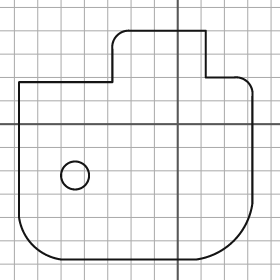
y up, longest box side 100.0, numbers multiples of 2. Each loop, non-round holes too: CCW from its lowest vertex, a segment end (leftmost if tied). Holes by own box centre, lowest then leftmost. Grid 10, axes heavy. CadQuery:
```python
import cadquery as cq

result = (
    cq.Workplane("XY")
    .moveTo(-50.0, -58.0)
    .lineTo(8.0, -58.0)
    .threePointArc((24.0, -50.0), (32.0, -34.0))
    .lineTo(32.0, 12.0)
    .threePointArc((30.0, 18.0), (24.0, 20.0))
    .lineTo(12.0, 20.0)
    .lineTo(12.0, 40.0)
    .lineTo(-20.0, 40.0)
    .threePointArc((-26.0, 38.0), (-28.0, 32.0))
    .lineTo(-28.0, 18.0)
    .lineTo(-68.0, 18.0)
    .lineTo(-68.0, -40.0)
    .threePointArc((-62.0, -52.0), (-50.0, -58.0))
    .close()
    .moveTo(-44.0, -22.0)
    .circle(6.0)
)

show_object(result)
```